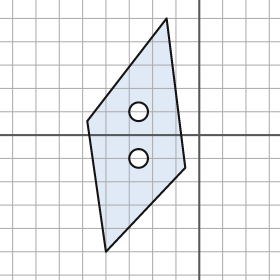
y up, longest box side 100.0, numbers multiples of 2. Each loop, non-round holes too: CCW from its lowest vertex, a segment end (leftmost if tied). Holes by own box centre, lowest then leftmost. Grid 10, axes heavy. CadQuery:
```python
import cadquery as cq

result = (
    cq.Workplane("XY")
    .moveTo(-40.0, -50.0)
    .lineTo(-6.0, -14.0)
    .lineTo(-14.0, 50.0)
    .lineTo(-48.0, 6.0)
    .close()
    .moveTo(-26.0, -10.0)
    .circle(4.0)
    .moveTo(-26.0, 10.0)
    .circle(4.0)
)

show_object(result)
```